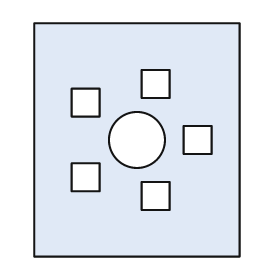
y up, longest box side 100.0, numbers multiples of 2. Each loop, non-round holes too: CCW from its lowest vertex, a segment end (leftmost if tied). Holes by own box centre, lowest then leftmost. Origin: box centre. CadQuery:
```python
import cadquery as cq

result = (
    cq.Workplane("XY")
    .moveTo(-44.0, -50.0)
    .lineTo(44.0, -50.0)
    .lineTo(44.0, 50.0)
    .lineTo(-44.0, 50.0)
    .close()
    .moveTo(2.0, -30.0)
    .lineTo(14.0, -30.0)
    .lineTo(14.0, -18.0)
    .lineTo(2.0, -18.0)
    .close()
    .moveTo(-28.0, -22.0)
    .lineTo(-16.0, -22.0)
    .lineTo(-16.0, -10.0)
    .lineTo(-28.0, -10.0)
    .close()
    .moveTo(0.0, 0.0)
    .circle(12.0)
    .moveTo(20.0, -6.0)
    .lineTo(32.0, -6.0)
    .lineTo(32.0, 6.0)
    .lineTo(20.0, 6.0)
    .close()
    .moveTo(-28.0, 10.0)
    .lineTo(-16.0, 10.0)
    .lineTo(-16.0, 22.0)
    .lineTo(-28.0, 22.0)
    .close()
    .moveTo(2.0, 18.0)
    .lineTo(14.0, 18.0)
    .lineTo(14.0, 30.0)
    .lineTo(2.0, 30.0)
    .close()
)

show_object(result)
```